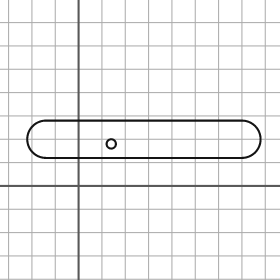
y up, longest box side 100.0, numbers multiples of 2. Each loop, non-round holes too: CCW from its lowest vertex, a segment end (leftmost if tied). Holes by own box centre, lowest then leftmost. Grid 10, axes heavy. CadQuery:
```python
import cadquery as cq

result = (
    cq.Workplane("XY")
    .moveTo(-14.0, 12.0)
    .lineTo(70.0, 12.0)
    .threePointArc((78.0, 20.0), (70.0, 28.0))
    .lineTo(-14.0, 28.0)
    .threePointArc((-22.0, 20.0), (-14.0, 12.0))
    .close()
    .moveTo(14.0, 18.0)
    .circle(2.0)
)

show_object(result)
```